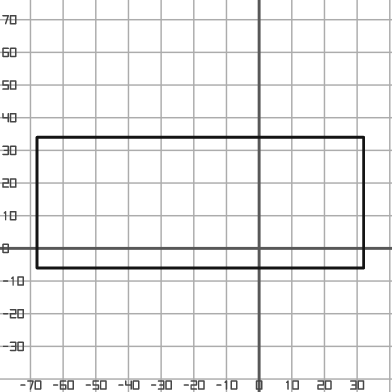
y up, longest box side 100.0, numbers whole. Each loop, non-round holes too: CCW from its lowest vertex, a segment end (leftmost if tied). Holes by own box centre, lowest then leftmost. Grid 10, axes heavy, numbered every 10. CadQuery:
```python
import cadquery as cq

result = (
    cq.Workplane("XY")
    .moveTo(-68.0, -6.0)
    .lineTo(32.0, -6.0)
    .lineTo(32.0, 34.0)
    .lineTo(-68.0, 34.0)
    .close()
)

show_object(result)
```